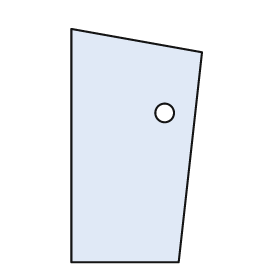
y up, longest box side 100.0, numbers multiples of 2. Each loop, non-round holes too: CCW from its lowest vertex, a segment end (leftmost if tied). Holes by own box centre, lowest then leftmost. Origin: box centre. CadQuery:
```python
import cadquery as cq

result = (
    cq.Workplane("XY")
    .moveTo(-28.0, -50.0)
    .lineTo(18.0, -50.0)
    .lineTo(28.0, 40.0)
    .lineTo(-28.0, 50.0)
    .close()
    .moveTo(12.0, 14.0)
    .circle(4.0)
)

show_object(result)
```